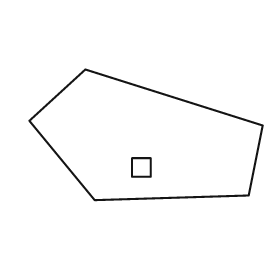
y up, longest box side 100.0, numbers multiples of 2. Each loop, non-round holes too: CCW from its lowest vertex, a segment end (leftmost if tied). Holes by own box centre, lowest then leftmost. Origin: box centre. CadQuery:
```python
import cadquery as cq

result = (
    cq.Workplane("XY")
    .moveTo(-22.0, -28.0)
    .lineTo(44.0, -26.0)
    .lineTo(50.0, 4.0)
    .lineTo(-26.0, 28.0)
    .lineTo(-50.0, 6.0)
    .close()
    .moveTo(-6.0, -18.0)
    .lineTo(2.0, -18.0)
    .lineTo(2.0, -10.0)
    .lineTo(-6.0, -10.0)
    .close()
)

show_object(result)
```